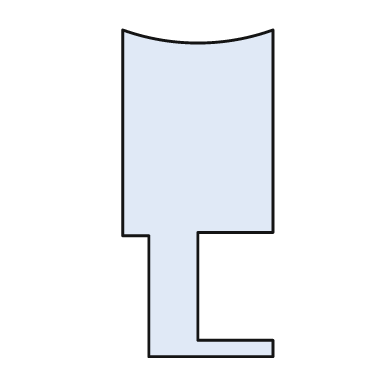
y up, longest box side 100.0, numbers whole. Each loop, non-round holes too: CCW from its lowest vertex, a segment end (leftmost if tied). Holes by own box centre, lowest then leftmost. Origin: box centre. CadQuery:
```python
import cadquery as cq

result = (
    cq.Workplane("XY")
    .moveTo(-15.0, -50.0)
    .lineTo(23.0, -50.0)
    .lineTo(23.0, -45.0)
    .lineTo(0.0, -45.0)
    .lineTo(0.0, -12.0)
    .lineTo(23.0, -12.0)
    .lineTo(23.0, 50.0)
    .threePointArc((0.0, 46.0), (-23.0, 50.0))
    .lineTo(-23.0, -13.0)
    .lineTo(-15.0, -13.0)
    .close()
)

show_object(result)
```